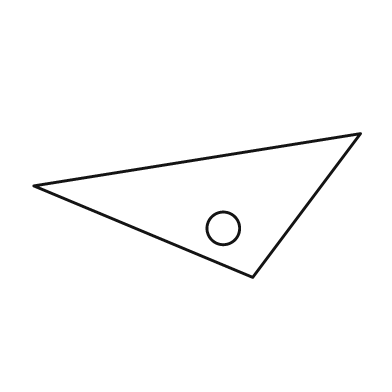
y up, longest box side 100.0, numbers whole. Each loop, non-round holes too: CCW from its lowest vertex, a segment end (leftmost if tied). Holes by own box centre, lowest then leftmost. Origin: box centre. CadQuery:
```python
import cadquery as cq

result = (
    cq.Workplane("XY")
    .moveTo(17.0, -22.0)
    .lineTo(50.0, 22.0)
    .lineTo(-50.0, 6.0)
    .close()
    .moveTo(8.0, -7.0)
    .circle(5.0)
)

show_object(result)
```